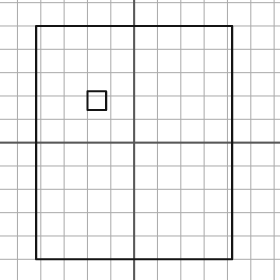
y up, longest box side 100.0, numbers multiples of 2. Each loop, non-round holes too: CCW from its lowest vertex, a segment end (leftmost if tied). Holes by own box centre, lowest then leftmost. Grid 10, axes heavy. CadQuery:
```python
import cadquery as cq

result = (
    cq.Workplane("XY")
    .moveTo(-42.0, -50.0)
    .lineTo(42.0, -50.0)
    .lineTo(42.0, 50.0)
    .lineTo(-42.0, 50.0)
    .close()
    .moveTo(-20.0, 14.0)
    .lineTo(-12.0, 14.0)
    .lineTo(-12.0, 22.0)
    .lineTo(-20.0, 22.0)
    .close()
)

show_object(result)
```